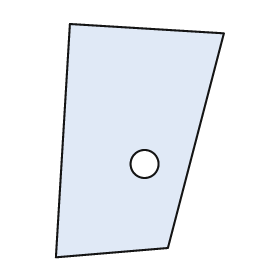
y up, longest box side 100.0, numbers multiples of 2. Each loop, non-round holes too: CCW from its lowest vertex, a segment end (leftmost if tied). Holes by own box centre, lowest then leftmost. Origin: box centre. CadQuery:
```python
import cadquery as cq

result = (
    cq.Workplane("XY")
    .moveTo(-36.0, -50.0)
    .lineTo(12.0, -46.0)
    .lineTo(36.0, 46.0)
    .lineTo(-30.0, 50.0)
    .close()
    .moveTo(2.0, -10.0)
    .circle(6.0)
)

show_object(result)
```